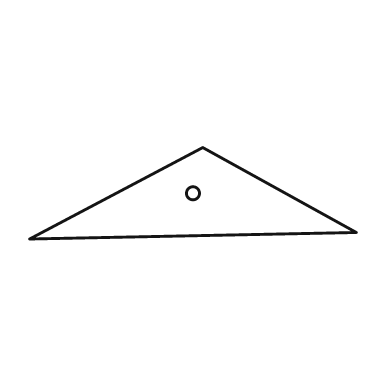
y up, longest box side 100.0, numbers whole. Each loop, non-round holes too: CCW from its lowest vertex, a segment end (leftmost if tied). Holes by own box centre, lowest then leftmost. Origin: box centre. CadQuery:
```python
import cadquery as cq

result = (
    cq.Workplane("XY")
    .moveTo(-50.0, -14.0)
    .lineTo(50.0, -12.0)
    .lineTo(3.0, 14.0)
    .close()
    .moveTo(0.0, 0.0)
    .circle(2.0)
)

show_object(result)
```